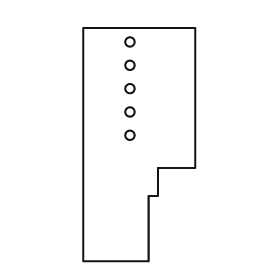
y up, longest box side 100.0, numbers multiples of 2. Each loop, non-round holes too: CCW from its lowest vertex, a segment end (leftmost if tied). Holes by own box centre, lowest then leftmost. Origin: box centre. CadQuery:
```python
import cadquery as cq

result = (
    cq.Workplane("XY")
    .moveTo(-24.0, -50.0)
    .lineTo(4.0, -50.0)
    .lineTo(4.0, -22.0)
    .lineTo(8.0, -22.0)
    .lineTo(8.0, -10.0)
    .lineTo(24.0, -10.0)
    .lineTo(24.0, 50.0)
    .lineTo(-24.0, 50.0)
    .close()
    .moveTo(-4.0, 4.0)
    .circle(2.0)
    .moveTo(-4.0, 14.0)
    .circle(2.0)
    .moveTo(-4.0, 24.0)
    .circle(2.0)
    .moveTo(-4.0, 34.0)
    .circle(2.0)
    .moveTo(-4.0, 44.0)
    .circle(2.0)
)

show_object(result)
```